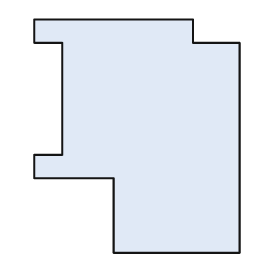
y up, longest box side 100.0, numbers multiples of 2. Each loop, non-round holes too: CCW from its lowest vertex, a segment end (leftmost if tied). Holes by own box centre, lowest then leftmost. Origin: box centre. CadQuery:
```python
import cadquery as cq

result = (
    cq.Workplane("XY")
    .moveTo(-10.0, -50.0)
    .lineTo(44.0, -50.0)
    .lineTo(44.0, 40.0)
    .lineTo(24.0, 40.0)
    .lineTo(24.0, 50.0)
    .lineTo(-44.0, 50.0)
    .lineTo(-44.0, 40.0)
    .lineTo(-32.0, 40.0)
    .lineTo(-32.0, -8.0)
    .lineTo(-44.0, -8.0)
    .lineTo(-44.0, -18.0)
    .lineTo(-10.0, -18.0)
    .close()
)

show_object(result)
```